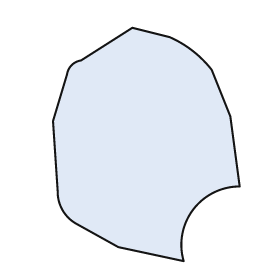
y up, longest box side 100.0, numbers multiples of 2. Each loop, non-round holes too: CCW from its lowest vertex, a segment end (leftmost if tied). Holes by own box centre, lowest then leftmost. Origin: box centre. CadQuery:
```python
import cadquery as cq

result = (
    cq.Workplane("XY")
    .moveTo(16.0, -50.0)
    .threePointArc((20.0, -28.0), (40.0, -18.0))
    .lineTo(36.0, 12.0)
    .lineTo(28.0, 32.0)
    .threePointArc((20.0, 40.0), (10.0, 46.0))
    .lineTo(-6.0, 50.0)
    .lineTo(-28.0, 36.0)
    .threePointArc((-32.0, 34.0), (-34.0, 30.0))
    .lineTo(-40.0, 10.0)
    .lineTo(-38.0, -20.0)
    .threePointArc((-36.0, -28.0), (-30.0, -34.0))
    .lineTo(-12.0, -44.0)
    .close()
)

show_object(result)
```